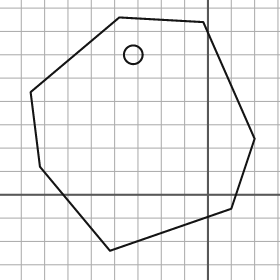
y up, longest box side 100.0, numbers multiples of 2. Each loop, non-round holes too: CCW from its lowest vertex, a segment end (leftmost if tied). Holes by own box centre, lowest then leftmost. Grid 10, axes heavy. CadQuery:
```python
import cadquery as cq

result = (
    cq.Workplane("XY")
    .moveTo(-42.0, -24.0)
    .lineTo(10.0, -6.0)
    .lineTo(20.0, 24.0)
    .lineTo(-2.0, 74.0)
    .lineTo(-38.0, 76.0)
    .lineTo(-76.0, 44.0)
    .lineTo(-72.0, 12.0)
    .close()
    .moveTo(-32.0, 60.0)
    .circle(4.0)
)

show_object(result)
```